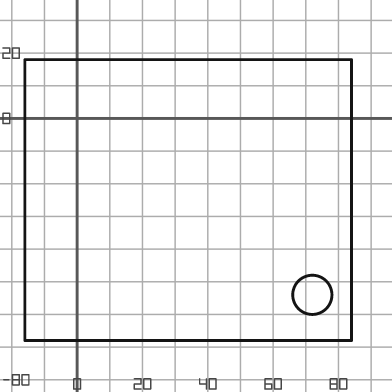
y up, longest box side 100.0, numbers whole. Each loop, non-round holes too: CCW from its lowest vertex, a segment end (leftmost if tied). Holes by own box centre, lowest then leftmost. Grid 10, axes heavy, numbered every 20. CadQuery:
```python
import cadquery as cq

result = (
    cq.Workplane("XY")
    .moveTo(-16.0, -68.0)
    .lineTo(84.0, -68.0)
    .lineTo(84.0, 18.0)
    .lineTo(-16.0, 18.0)
    .close()
    .moveTo(72.0, -54.0)
    .circle(6.0)
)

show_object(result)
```